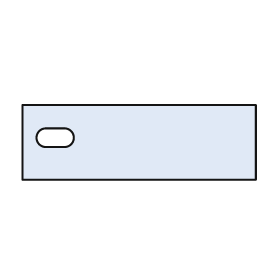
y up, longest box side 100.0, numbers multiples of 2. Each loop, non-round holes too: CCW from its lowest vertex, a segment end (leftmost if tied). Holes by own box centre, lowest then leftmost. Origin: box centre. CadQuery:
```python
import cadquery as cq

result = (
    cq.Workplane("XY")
    .moveTo(-50.0, -16.0)
    .lineTo(50.0, -16.0)
    .lineTo(50.0, 16.0)
    .lineTo(-50.0, 16.0)
    .close()
    .moveTo(-40.0, -2.0)
    .lineTo(-32.0, -2.0)
    .threePointArc((-28.0, 2.0), (-32.0, 6.0))
    .lineTo(-40.0, 6.0)
    .threePointArc((-44.0, 2.0), (-40.0, -2.0))
    .close()
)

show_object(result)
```